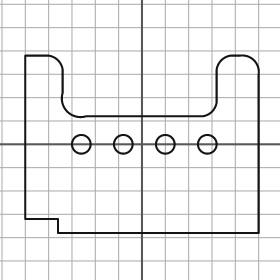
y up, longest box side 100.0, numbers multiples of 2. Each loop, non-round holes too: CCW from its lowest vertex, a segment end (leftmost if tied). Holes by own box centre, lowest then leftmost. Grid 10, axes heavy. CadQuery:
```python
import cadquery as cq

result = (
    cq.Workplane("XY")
    .moveTo(-36.0, -38.0)
    .lineTo(50.0, -38.0)
    .lineTo(50.0, 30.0)
    .threePointArc((48.0, 36.0), (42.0, 38.0))
    .lineTo(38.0, 38.0)
    .threePointArc((34.0, 36.0), (32.0, 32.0))
    .lineTo(32.0, 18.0)
    .threePointArc((30.0, 14.0), (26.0, 12.0))
    .lineTo(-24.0, 12.0)
    .threePointArc((-32.0, 14.0), (-34.0, 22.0))
    .lineTo(-34.0, 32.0)
    .threePointArc((-36.0, 36.0), (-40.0, 38.0))
    .lineTo(-50.0, 38.0)
    .lineTo(-50.0, -32.0)
    .lineTo(-36.0, -32.0)
    .close()
    .moveTo(-26.0, 0.0)
    .circle(4.0)
    .moveTo(-8.0, 0.0)
    .circle(4.0)
    .moveTo(10.0, 0.0)
    .circle(4.0)
    .moveTo(28.0, 0.0)
    .circle(4.0)
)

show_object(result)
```